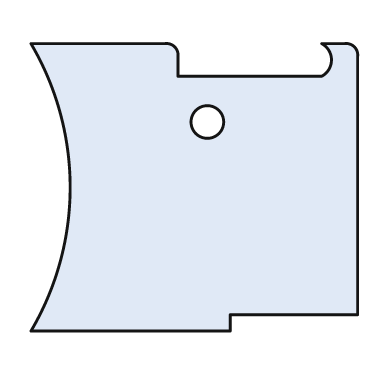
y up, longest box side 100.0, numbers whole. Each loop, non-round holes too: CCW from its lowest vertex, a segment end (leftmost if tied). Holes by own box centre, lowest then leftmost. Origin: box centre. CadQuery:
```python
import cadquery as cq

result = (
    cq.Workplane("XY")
    .moveTo(-50.0, -44.0)
    .lineTo(11.0, -44.0)
    .lineTo(11.0, -39.0)
    .lineTo(50.0, -39.0)
    .lineTo(50.0, 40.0)
    .threePointArc((49.0, 43.0), (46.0, 44.0))
    .lineTo(39.0, 44.0)
    .threePointArc((42.0, 39.0), (39.0, 34.0))
    .lineTo(-5.0, 34.0)
    .lineTo(-5.0, 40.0)
    .threePointArc((-6.0, 43.0), (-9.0, 44.0))
    .lineTo(-50.0, 44.0)
    .threePointArc((-38.0, 0.0), (-50.0, -44.0))
    .close()
    .moveTo(4.0, 20.0)
    .circle(5.0)
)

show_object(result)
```